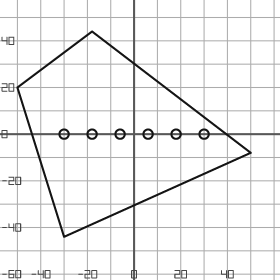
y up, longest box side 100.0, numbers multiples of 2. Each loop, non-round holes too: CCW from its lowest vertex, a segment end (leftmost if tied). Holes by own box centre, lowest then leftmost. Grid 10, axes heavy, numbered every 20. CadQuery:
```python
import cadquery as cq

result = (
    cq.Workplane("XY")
    .moveTo(-30.0, -44.0)
    .lineTo(50.0, -8.0)
    .lineTo(-18.0, 44.0)
    .lineTo(-50.0, 20.0)
    .close()
    .moveTo(-30.0, 0.0)
    .circle(2.0)
    .moveTo(-18.0, 0.0)
    .circle(2.0)
    .moveTo(-6.0, 0.0)
    .circle(2.0)
    .moveTo(6.0, 0.0)
    .circle(2.0)
    .moveTo(18.0, 0.0)
    .circle(2.0)
    .moveTo(30.0, 0.0)
    .circle(2.0)
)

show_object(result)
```